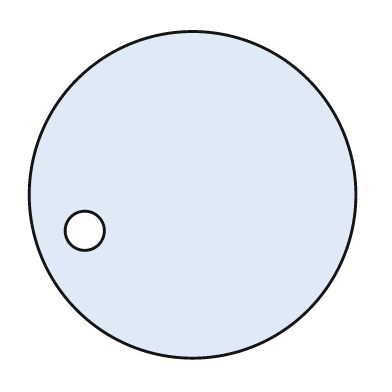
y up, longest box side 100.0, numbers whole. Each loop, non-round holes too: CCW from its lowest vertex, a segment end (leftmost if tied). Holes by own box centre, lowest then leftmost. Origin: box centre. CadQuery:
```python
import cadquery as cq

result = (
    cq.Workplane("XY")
    .moveTo(0.0, 0.0)
    .circle(50.0)
    .moveTo(-33.0, -11.0)
    .circle(6.0)
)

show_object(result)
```